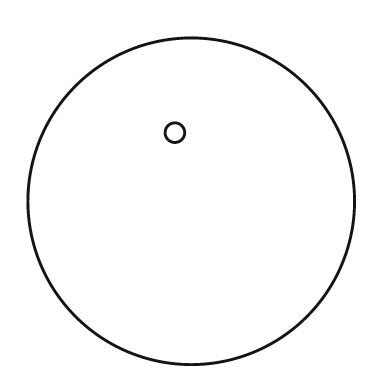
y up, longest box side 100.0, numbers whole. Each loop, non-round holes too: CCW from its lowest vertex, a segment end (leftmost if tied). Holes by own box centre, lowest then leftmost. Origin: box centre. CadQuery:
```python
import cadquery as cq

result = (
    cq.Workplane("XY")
    .moveTo(0.0, 0.0)
    .circle(50.0)
    .moveTo(-5.0, 21.0)
    .circle(3.0)
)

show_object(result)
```